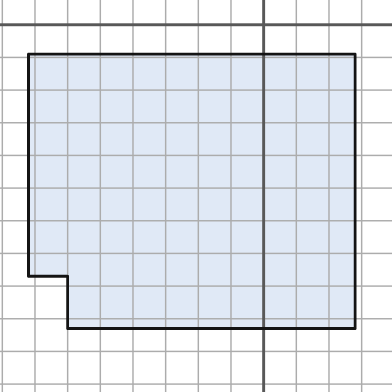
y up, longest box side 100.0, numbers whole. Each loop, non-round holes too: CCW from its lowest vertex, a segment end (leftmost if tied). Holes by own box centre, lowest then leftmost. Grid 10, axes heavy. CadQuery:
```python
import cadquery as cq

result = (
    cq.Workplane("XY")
    .moveTo(-60.0, -93.0)
    .lineTo(28.0, -93.0)
    .lineTo(28.0, -9.0)
    .lineTo(-72.0, -9.0)
    .lineTo(-72.0, -77.0)
    .lineTo(-60.0, -77.0)
    .close()
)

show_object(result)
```